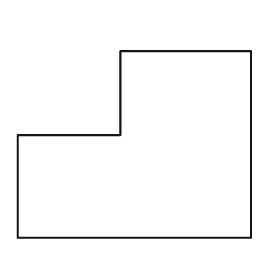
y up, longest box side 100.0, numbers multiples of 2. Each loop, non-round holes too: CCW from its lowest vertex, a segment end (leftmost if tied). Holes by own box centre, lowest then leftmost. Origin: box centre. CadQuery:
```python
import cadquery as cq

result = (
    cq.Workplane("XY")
    .moveTo(-50.0, -40.0)
    .lineTo(50.0, -40.0)
    .lineTo(50.0, 40.0)
    .lineTo(-6.0, 40.0)
    .lineTo(-6.0, 4.0)
    .lineTo(-50.0, 4.0)
    .close()
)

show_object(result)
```